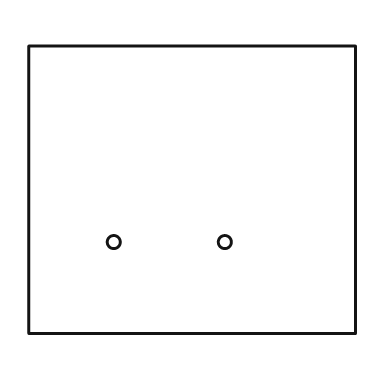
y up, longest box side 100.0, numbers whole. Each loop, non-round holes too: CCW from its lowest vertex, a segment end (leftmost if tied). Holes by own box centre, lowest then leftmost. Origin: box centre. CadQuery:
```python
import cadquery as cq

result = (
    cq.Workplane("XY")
    .moveTo(-50.0, -44.0)
    .lineTo(50.0, -44.0)
    .lineTo(50.0, 44.0)
    .lineTo(-50.0, 44.0)
    .close()
    .moveTo(-24.0, -16.0)
    .circle(2.0)
    .moveTo(10.0, -16.0)
    .circle(2.0)
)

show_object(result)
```